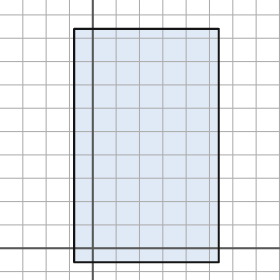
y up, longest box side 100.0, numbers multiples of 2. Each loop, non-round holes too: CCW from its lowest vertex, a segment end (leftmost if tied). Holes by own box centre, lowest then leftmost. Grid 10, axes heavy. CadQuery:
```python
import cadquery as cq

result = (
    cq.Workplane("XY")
    .moveTo(-8.0, -6.0)
    .lineTo(54.0, -6.0)
    .lineTo(54.0, 94.0)
    .lineTo(-8.0, 94.0)
    .close()
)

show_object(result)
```